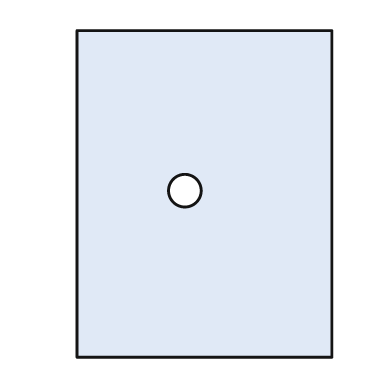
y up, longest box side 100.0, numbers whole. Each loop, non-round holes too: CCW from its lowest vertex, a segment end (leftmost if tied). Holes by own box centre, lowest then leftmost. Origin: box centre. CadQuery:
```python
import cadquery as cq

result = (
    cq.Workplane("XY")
    .moveTo(-39.0, -50.0)
    .lineTo(39.0, -50.0)
    .lineTo(39.0, 50.0)
    .lineTo(-39.0, 50.0)
    .close()
    .moveTo(-6.0, 1.0)
    .circle(5.0)
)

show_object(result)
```